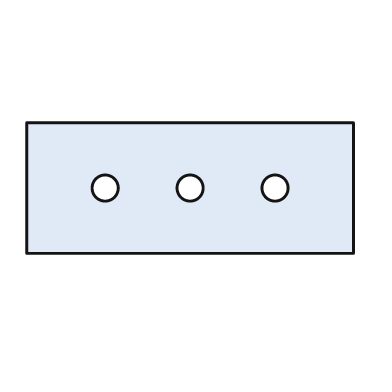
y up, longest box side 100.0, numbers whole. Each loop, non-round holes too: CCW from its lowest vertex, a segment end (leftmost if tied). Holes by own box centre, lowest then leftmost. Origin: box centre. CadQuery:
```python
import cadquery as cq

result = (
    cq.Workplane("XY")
    .moveTo(-50.0, -20.0)
    .lineTo(50.0, -20.0)
    .lineTo(50.0, 20.0)
    .lineTo(-50.0, 20.0)
    .close()
    .moveTo(-26.0, 0.0)
    .circle(4.0)
    .moveTo(0.0, 0.0)
    .circle(4.0)
    .moveTo(26.0, 0.0)
    .circle(4.0)
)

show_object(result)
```